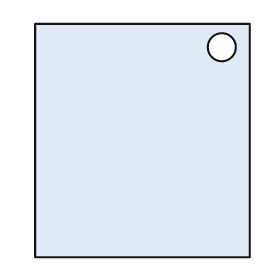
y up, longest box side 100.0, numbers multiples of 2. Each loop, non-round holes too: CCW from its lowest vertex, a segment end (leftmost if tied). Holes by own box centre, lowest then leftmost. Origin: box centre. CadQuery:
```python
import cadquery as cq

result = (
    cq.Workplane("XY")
    .moveTo(-46.0, -50.0)
    .lineTo(46.0, -50.0)
    .lineTo(46.0, 50.0)
    .lineTo(-46.0, 50.0)
    .close()
    .moveTo(34.0, 40.0)
    .circle(6.0)
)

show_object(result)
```